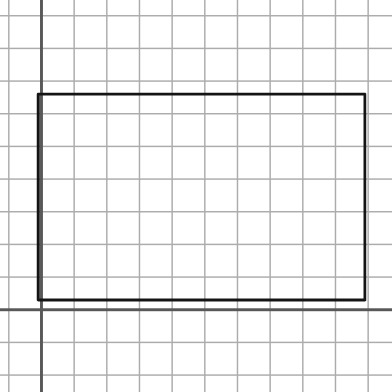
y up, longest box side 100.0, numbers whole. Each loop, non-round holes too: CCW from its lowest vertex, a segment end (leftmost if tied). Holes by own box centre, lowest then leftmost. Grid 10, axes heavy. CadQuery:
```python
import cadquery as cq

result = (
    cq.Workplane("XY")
    .moveTo(-1.0, 3.0)
    .lineTo(99.0, 3.0)
    .lineTo(99.0, 66.0)
    .lineTo(-1.0, 66.0)
    .close()
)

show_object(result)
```